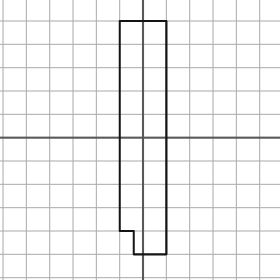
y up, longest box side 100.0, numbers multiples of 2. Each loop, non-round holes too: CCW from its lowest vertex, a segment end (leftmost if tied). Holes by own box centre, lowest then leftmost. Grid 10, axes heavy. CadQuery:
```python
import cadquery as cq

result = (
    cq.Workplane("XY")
    .moveTo(-4.0, -50.0)
    .lineTo(10.0, -50.0)
    .lineTo(10.0, 50.0)
    .lineTo(-10.0, 50.0)
    .lineTo(-10.0, -40.0)
    .lineTo(-4.0, -40.0)
    .close()
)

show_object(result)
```